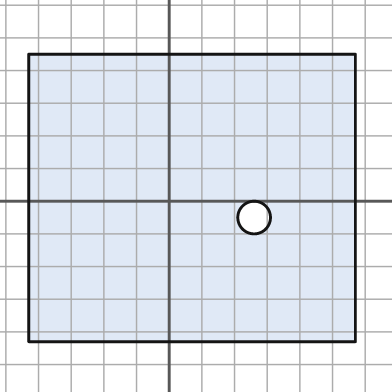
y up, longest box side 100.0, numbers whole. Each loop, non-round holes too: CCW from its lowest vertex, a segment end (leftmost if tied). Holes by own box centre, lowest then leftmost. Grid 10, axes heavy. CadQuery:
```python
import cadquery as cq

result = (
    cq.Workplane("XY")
    .moveTo(-43.0, -43.0)
    .lineTo(57.0, -43.0)
    .lineTo(57.0, 45.0)
    .lineTo(-43.0, 45.0)
    .close()
    .moveTo(26.0, -5.0)
    .circle(5.0)
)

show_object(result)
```